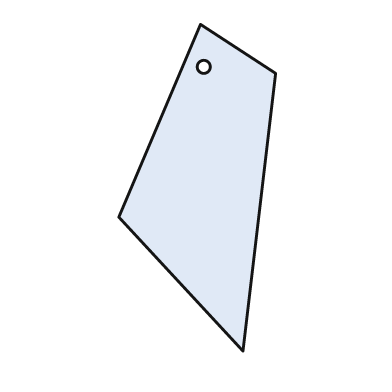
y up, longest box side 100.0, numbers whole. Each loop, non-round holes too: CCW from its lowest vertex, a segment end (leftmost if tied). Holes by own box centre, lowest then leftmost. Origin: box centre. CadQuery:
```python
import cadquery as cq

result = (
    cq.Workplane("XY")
    .moveTo(14.0, -50.0)
    .lineTo(24.0, 35.0)
    .lineTo(1.0, 50.0)
    .lineTo(-24.0, -9.0)
    .close()
    .moveTo(2.0, 37.0)
    .circle(2.0)
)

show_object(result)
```